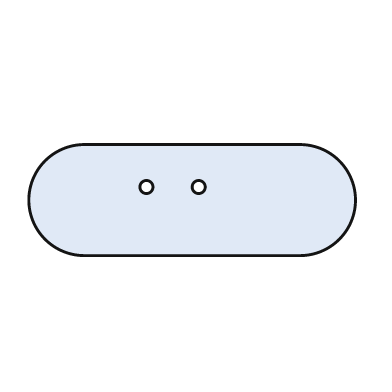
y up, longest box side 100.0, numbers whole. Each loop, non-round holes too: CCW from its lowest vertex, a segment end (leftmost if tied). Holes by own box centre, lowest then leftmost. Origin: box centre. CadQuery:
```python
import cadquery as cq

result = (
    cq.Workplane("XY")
    .moveTo(-33.0, -17.0)
    .lineTo(33.0, -17.0)
    .threePointArc((50.0, 0.0), (33.0, 17.0))
    .lineTo(-33.0, 17.0)
    .threePointArc((-50.0, 0.0), (-33.0, -17.0))
    .close()
    .moveTo(-14.0, 4.0)
    .circle(2.0)
    .moveTo(2.0, 4.0)
    .circle(2.0)
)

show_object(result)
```